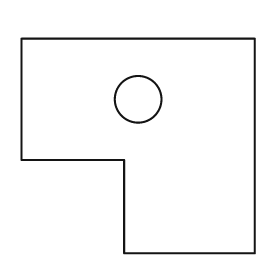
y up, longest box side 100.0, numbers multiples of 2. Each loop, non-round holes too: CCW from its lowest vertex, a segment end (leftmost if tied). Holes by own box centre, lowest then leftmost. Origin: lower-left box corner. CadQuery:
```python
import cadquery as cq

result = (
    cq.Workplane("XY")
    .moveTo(44.0, 0.0)
    .lineTo(100.0, 0.0)
    .lineTo(100.0, 92.0)
    .lineTo(0.0, 92.0)
    .lineTo(0.0, 40.0)
    .lineTo(44.0, 40.0)
    .close()
    .moveTo(50.0, 66.0)
    .circle(10.0)
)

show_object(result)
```